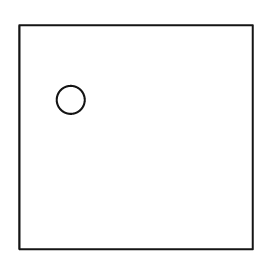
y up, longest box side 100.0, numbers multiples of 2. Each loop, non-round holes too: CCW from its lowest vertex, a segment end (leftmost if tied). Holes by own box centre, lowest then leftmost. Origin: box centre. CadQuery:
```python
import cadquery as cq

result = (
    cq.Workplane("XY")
    .moveTo(-50.0, -48.0)
    .lineTo(50.0, -48.0)
    .lineTo(50.0, 48.0)
    .lineTo(-50.0, 48.0)
    .close()
    .moveTo(-28.0, 16.0)
    .circle(6.0)
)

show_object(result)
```